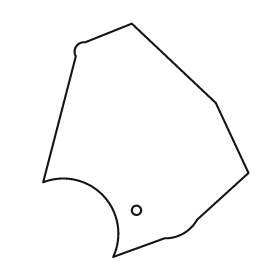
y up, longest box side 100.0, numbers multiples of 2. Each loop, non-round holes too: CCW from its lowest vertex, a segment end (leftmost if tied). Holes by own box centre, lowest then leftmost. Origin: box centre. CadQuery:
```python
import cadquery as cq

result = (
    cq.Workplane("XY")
    .moveTo(-14.0, -50.0)
    .lineTo(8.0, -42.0)
    .threePointArc((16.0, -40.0), (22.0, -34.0))
    .lineTo(44.0, -14.0)
    .lineTo(30.0, 16.0)
    .lineTo(-6.0, 50.0)
    .lineTo(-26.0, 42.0)
    .threePointArc((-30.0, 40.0), (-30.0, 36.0))
    .lineTo(-44.0, -18.0)
    .threePointArc((-18.0, -24.0), (-14.0, -50.0))
    .close()
    .moveTo(-4.0, -30.0)
    .circle(2.0)
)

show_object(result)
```